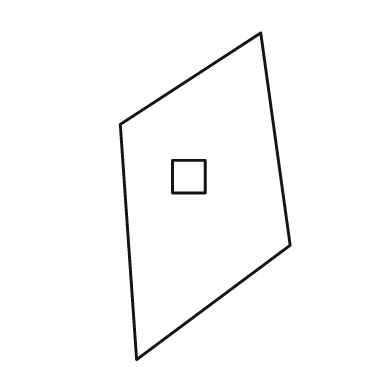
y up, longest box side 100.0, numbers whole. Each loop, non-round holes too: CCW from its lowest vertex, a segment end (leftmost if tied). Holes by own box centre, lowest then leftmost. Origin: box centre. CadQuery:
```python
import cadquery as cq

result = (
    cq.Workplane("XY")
    .moveTo(-21.0, -50.0)
    .lineTo(26.0, -15.0)
    .lineTo(17.0, 50.0)
    .lineTo(-26.0, 22.0)
    .close()
    .moveTo(-10.0, 1.0)
    .lineTo(0.0, 1.0)
    .lineTo(0.0, 11.0)
    .lineTo(-10.0, 11.0)
    .close()
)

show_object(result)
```